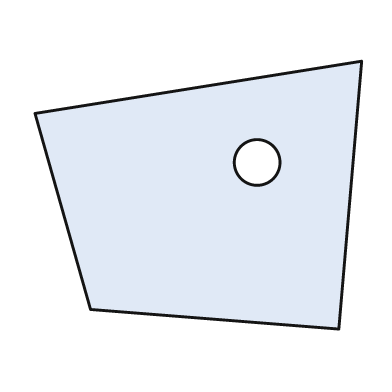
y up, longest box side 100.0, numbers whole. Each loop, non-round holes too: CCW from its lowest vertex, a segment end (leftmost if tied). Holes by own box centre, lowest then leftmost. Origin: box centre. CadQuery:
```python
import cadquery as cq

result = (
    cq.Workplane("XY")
    .moveTo(43.0, -41.0)
    .lineTo(50.0, 41.0)
    .lineTo(-50.0, 25.0)
    .lineTo(-33.0, -35.0)
    .close()
    .moveTo(18.0, 10.0)
    .circle(7.0)
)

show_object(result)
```